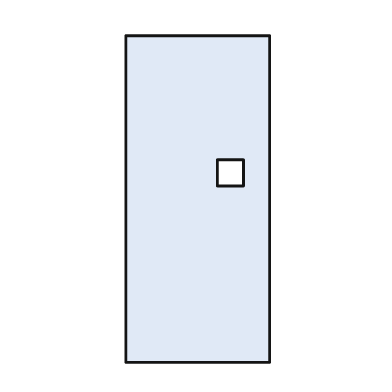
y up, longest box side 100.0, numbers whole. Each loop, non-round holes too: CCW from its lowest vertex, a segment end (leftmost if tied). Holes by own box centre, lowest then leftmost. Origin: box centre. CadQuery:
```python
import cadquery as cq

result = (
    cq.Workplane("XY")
    .moveTo(-22.0, -50.0)
    .lineTo(22.0, -50.0)
    .lineTo(22.0, 50.0)
    .lineTo(-22.0, 50.0)
    .close()
    .moveTo(6.0, 4.0)
    .lineTo(14.0, 4.0)
    .lineTo(14.0, 12.0)
    .lineTo(6.0, 12.0)
    .close()
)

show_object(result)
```